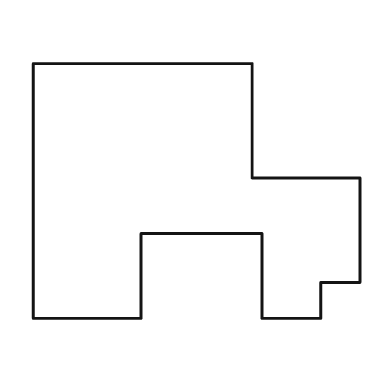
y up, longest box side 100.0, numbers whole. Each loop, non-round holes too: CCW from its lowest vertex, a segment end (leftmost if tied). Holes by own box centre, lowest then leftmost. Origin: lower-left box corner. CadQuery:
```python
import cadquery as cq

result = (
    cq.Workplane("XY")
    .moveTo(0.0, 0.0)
    .lineTo(33.0, 0.0)
    .lineTo(33.0, 26.0)
    .lineTo(70.0, 26.0)
    .lineTo(70.0, 0.0)
    .lineTo(88.0, 0.0)
    .lineTo(88.0, 11.0)
    .lineTo(100.0, 11.0)
    .lineTo(100.0, 43.0)
    .lineTo(67.0, 43.0)
    .lineTo(67.0, 78.0)
    .lineTo(0.0, 78.0)
    .close()
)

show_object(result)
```